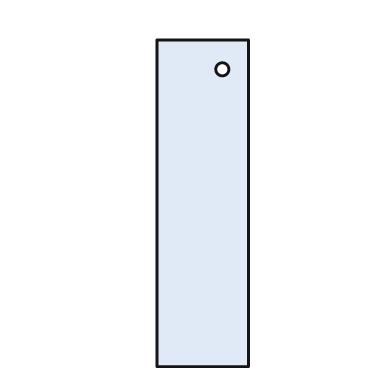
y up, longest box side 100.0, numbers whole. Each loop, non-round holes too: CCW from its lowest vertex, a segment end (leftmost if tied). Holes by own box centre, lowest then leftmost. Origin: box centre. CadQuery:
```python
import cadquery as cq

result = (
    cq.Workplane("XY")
    .moveTo(-14.0, -50.0)
    .lineTo(14.0, -50.0)
    .lineTo(14.0, 50.0)
    .lineTo(-14.0, 50.0)
    .close()
    .moveTo(6.0, 41.0)
    .circle(2.0)
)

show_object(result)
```